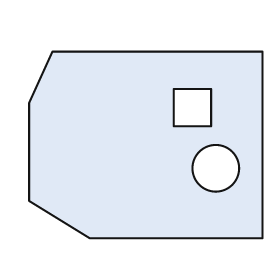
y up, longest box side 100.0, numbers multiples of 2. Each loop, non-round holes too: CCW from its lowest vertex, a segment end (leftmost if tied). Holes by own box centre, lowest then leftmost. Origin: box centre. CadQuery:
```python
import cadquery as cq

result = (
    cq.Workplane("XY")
    .moveTo(-24.0, -40.0)
    .lineTo(50.0, -40.0)
    .lineTo(50.0, 40.0)
    .lineTo(-40.0, 40.0)
    .lineTo(-50.0, 18.0)
    .lineTo(-50.0, -24.0)
    .close()
    .moveTo(30.0, -10.0)
    .circle(10.0)
    .moveTo(12.0, 8.0)
    .lineTo(28.0, 8.0)
    .lineTo(28.0, 24.0)
    .lineTo(12.0, 24.0)
    .close()
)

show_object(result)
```